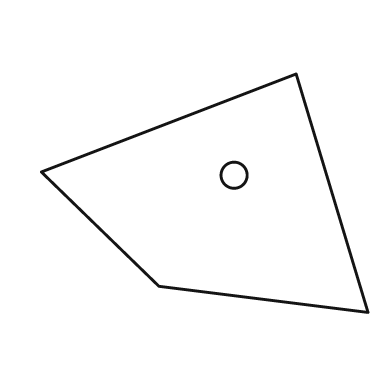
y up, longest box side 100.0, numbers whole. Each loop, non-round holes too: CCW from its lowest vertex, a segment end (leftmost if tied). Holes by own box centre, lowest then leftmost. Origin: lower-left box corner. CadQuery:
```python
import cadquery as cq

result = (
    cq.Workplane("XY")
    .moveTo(100.0, 0.0)
    .lineTo(78.0, 73.0)
    .lineTo(0.0, 43.0)
    .lineTo(36.0, 8.0)
    .close()
    .moveTo(59.0, 42.0)
    .circle(4.0)
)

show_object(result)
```